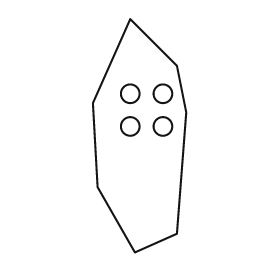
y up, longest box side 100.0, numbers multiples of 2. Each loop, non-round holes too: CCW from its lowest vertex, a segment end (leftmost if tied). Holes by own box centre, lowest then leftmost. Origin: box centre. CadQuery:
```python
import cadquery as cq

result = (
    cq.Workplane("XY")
    .moveTo(-2.0, -50.0)
    .lineTo(16.0, -42.0)
    .lineTo(20.0, 10.0)
    .lineTo(16.0, 30.0)
    .lineTo(-4.0, 50.0)
    .lineTo(-20.0, 14.0)
    .lineTo(-18.0, -22.0)
    .close()
    .moveTo(-4.0, 4.0)
    .circle(4.0)
    .moveTo(10.0, 4.0)
    .circle(4.0)
    .moveTo(-4.0, 18.0)
    .circle(4.0)
    .moveTo(10.0, 18.0)
    .circle(4.0)
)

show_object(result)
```